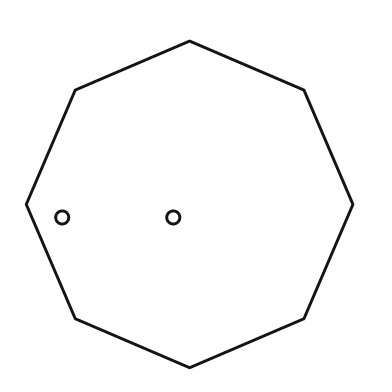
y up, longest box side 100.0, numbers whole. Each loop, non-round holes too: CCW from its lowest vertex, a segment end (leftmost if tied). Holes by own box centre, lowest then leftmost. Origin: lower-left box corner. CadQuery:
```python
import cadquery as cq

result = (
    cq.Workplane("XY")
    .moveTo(50.0, 0.0)
    .lineTo(85.0, 15.0)
    .lineTo(100.0, 50.0)
    .lineTo(85.0, 85.0)
    .lineTo(50.0, 100.0)
    .lineTo(15.0, 85.0)
    .lineTo(0.0, 50.0)
    .lineTo(15.0, 15.0)
    .close()
    .moveTo(11.0, 46.0)
    .circle(2.0)
    .moveTo(45.0, 46.0)
    .circle(2.0)
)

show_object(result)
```